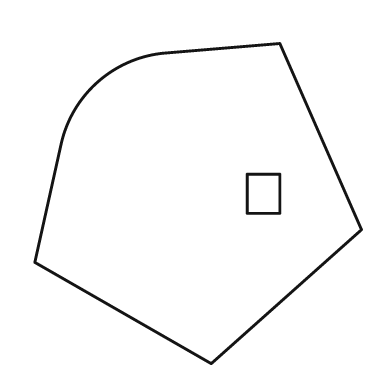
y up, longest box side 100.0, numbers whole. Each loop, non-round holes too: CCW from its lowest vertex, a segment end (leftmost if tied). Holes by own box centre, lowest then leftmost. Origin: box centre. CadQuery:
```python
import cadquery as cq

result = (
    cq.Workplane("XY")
    .moveTo(4.0, -49.0)
    .lineTo(50.0, -8.0)
    .lineTo(25.0, 49.0)
    .lineTo(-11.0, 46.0)
    .threePointArc((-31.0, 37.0), (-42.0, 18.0))
    .lineTo(-50.0, -18.0)
    .close()
    .moveTo(15.0, -3.0)
    .lineTo(25.0, -3.0)
    .lineTo(25.0, 9.0)
    .lineTo(15.0, 9.0)
    .close()
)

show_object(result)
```